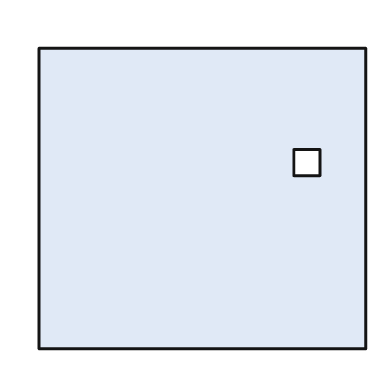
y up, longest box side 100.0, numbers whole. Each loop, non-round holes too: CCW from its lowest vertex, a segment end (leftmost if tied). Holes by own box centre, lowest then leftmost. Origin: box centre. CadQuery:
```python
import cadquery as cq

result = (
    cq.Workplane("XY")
    .moveTo(-50.0, -46.0)
    .lineTo(50.0, -46.0)
    .lineTo(50.0, 46.0)
    .lineTo(-50.0, 46.0)
    .close()
    .moveTo(28.0, 7.0)
    .lineTo(36.0, 7.0)
    .lineTo(36.0, 15.0)
    .lineTo(28.0, 15.0)
    .close()
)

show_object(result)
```